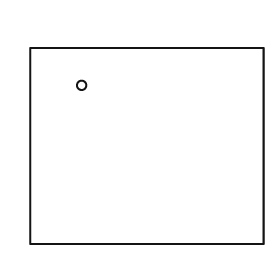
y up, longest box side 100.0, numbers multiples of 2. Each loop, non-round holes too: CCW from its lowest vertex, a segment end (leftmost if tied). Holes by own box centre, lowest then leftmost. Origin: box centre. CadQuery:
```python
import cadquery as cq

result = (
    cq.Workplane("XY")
    .moveTo(-50.0, -42.0)
    .lineTo(50.0, -42.0)
    .lineTo(50.0, 42.0)
    .lineTo(-50.0, 42.0)
    .close()
    .moveTo(-28.0, 26.0)
    .circle(2.0)
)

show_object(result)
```